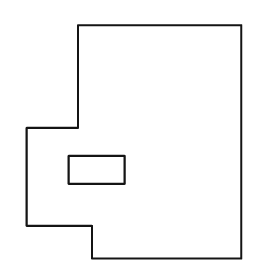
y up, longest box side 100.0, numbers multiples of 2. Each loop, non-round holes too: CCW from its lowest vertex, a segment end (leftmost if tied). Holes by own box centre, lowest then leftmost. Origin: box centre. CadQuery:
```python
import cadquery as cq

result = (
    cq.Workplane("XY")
    .moveTo(-18.0, -50.0)
    .lineTo(46.0, -50.0)
    .lineTo(46.0, 50.0)
    .lineTo(-24.0, 50.0)
    .lineTo(-24.0, 6.0)
    .lineTo(-46.0, 6.0)
    .lineTo(-46.0, -36.0)
    .lineTo(-18.0, -36.0)
    .close()
    .moveTo(-28.0, -18.0)
    .lineTo(-4.0, -18.0)
    .lineTo(-4.0, -6.0)
    .lineTo(-28.0, -6.0)
    .close()
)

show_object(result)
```